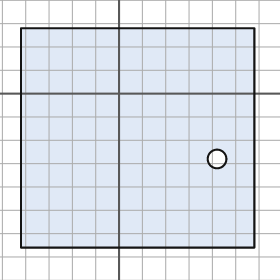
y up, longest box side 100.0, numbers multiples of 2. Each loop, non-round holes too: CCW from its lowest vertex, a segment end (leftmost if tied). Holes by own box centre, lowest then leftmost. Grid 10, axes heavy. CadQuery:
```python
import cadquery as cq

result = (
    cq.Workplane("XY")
    .moveTo(-42.0, -66.0)
    .lineTo(58.0, -66.0)
    .lineTo(58.0, 28.0)
    .lineTo(-42.0, 28.0)
    .close()
    .moveTo(42.0, -28.0)
    .circle(4.0)
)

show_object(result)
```